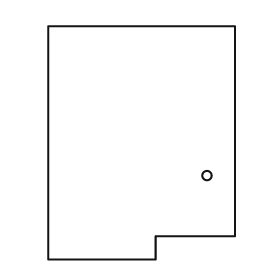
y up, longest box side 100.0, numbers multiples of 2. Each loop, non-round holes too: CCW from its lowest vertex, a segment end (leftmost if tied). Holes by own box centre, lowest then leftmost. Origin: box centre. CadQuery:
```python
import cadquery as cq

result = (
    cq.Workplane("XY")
    .moveTo(-40.0, -50.0)
    .lineTo(6.0, -50.0)
    .lineTo(6.0, -40.0)
    .lineTo(40.0, -40.0)
    .lineTo(40.0, 50.0)
    .lineTo(-40.0, 50.0)
    .close()
    .moveTo(28.0, -14.0)
    .circle(2.0)
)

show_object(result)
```